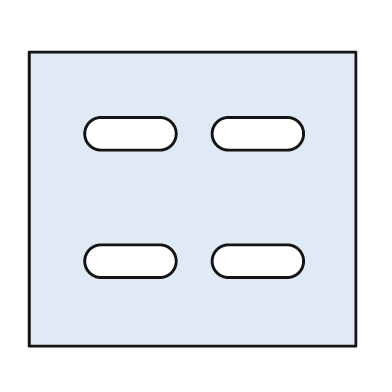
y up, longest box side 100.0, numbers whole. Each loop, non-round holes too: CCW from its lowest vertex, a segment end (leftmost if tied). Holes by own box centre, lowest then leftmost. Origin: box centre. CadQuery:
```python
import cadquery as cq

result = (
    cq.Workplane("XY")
    .moveTo(-50.0, -45.0)
    .lineTo(50.0, -45.0)
    .lineTo(50.0, 45.0)
    .lineTo(-50.0, 45.0)
    .close()
    .moveTo(-28.0, -24.0)
    .lineTo(-10.0, -24.0)
    .threePointArc((-5.0, -19.0), (-10.0, -14.0))
    .lineTo(-28.0, -14.0)
    .threePointArc((-33.0, -19.0), (-28.0, -24.0))
    .close()
    .moveTo(11.0, -24.0)
    .lineTo(29.0, -24.0)
    .threePointArc((34.0, -19.0), (29.0, -14.0))
    .lineTo(11.0, -14.0)
    .threePointArc((6.0, -19.0), (11.0, -24.0))
    .close()
    .moveTo(-28.0, 15.0)
    .lineTo(-10.0, 15.0)
    .threePointArc((-5.0, 20.0), (-10.0, 25.0))
    .lineTo(-28.0, 25.0)
    .threePointArc((-33.0, 20.0), (-28.0, 15.0))
    .close()
    .moveTo(11.0, 15.0)
    .lineTo(29.0, 15.0)
    .threePointArc((34.0, 20.0), (29.0, 25.0))
    .lineTo(11.0, 25.0)
    .threePointArc((6.0, 20.0), (11.0, 15.0))
    .close()
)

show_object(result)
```